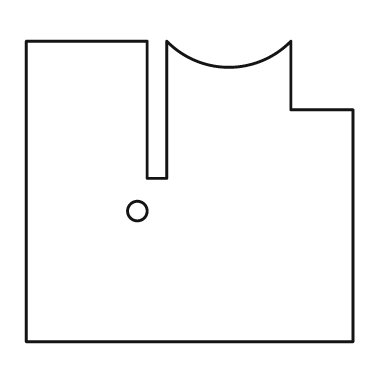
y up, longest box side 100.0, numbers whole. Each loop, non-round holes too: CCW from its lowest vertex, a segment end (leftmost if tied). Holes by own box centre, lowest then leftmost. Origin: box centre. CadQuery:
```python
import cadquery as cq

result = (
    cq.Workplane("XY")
    .moveTo(-50.0, -46.0)
    .lineTo(50.0, -46.0)
    .lineTo(50.0, 25.0)
    .lineTo(31.0, 25.0)
    .lineTo(31.0, 46.0)
    .threePointArc((12.0, 38.0), (-7.0, 46.0))
    .lineTo(-7.0, 4.0)
    .lineTo(-13.0, 4.0)
    .lineTo(-13.0, 46.0)
    .lineTo(-50.0, 46.0)
    .close()
    .moveTo(-16.0, -6.0)
    .circle(3.0)
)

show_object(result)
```